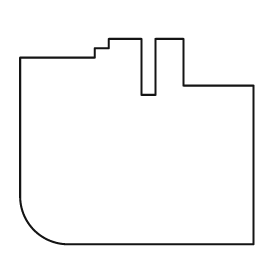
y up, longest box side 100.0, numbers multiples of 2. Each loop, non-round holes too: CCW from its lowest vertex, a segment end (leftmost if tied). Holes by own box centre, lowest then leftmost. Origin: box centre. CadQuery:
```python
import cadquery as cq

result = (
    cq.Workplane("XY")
    .moveTo(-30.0, -44.0)
    .lineTo(50.0, -44.0)
    .lineTo(50.0, 24.0)
    .lineTo(20.0, 24.0)
    .lineTo(20.0, 44.0)
    .lineTo(8.0, 44.0)
    .lineTo(8.0, 20.0)
    .lineTo(2.0, 20.0)
    .lineTo(2.0, 44.0)
    .lineTo(-12.0, 44.0)
    .lineTo(-12.0, 40.0)
    .lineTo(-18.0, 40.0)
    .lineTo(-18.0, 36.0)
    .lineTo(-50.0, 36.0)
    .lineTo(-50.0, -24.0)
    .threePointArc((-44.0, -38.0), (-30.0, -44.0))
    .close()
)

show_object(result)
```